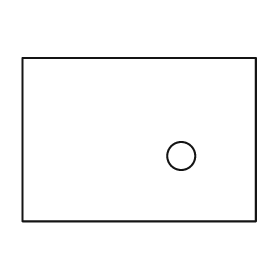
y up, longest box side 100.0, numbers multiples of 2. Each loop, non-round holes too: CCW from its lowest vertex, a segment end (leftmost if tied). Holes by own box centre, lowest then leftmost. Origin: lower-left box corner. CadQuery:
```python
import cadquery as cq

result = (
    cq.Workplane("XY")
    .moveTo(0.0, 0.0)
    .lineTo(100.0, 0.0)
    .lineTo(100.0, 70.0)
    .lineTo(0.0, 70.0)
    .close()
    .moveTo(68.0, 28.0)
    .circle(6.0)
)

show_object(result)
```